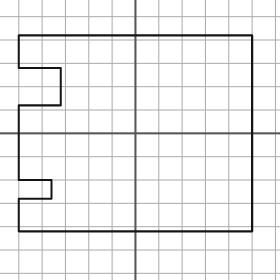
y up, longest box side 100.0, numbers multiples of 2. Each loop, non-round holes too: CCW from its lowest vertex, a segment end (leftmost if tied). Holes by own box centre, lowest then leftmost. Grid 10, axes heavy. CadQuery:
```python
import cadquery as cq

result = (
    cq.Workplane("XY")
    .moveTo(-50.0, -42.0)
    .lineTo(50.0, -42.0)
    .lineTo(50.0, 42.0)
    .lineTo(-50.0, 42.0)
    .lineTo(-50.0, 28.0)
    .lineTo(-32.0, 28.0)
    .lineTo(-32.0, 12.0)
    .lineTo(-50.0, 12.0)
    .lineTo(-50.0, -20.0)
    .lineTo(-36.0, -20.0)
    .lineTo(-36.0, -28.0)
    .lineTo(-50.0, -28.0)
    .close()
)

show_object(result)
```